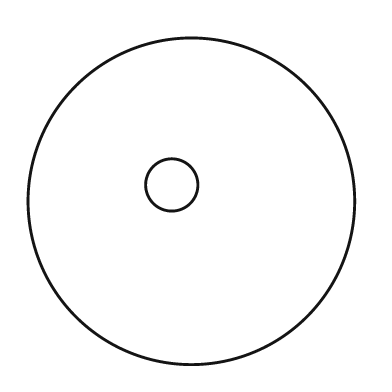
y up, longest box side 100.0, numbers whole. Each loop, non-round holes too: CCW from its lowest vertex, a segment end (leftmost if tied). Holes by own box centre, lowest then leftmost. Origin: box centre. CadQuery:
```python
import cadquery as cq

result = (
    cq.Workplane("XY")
    .moveTo(0.0, 0.0)
    .circle(50.0)
    .moveTo(-6.0, 5.0)
    .circle(8.0)
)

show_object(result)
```